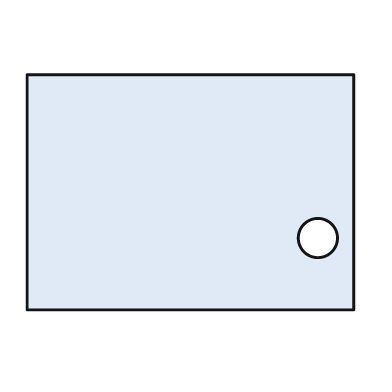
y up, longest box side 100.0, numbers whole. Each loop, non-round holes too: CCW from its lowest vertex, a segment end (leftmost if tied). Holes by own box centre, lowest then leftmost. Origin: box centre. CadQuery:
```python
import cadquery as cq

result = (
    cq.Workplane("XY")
    .moveTo(-50.0, -36.0)
    .lineTo(50.0, -36.0)
    .lineTo(50.0, 36.0)
    .lineTo(-50.0, 36.0)
    .close()
    .moveTo(39.0, -14.0)
    .circle(6.0)
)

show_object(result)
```